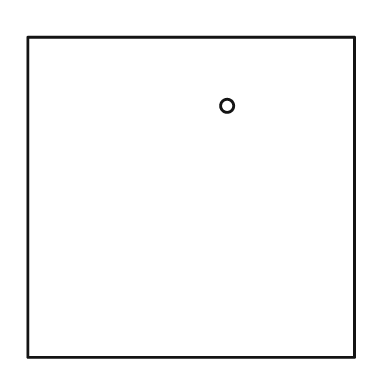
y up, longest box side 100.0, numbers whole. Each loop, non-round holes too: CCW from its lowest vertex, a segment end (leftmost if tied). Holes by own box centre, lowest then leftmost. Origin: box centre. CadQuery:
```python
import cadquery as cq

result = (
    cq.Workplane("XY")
    .moveTo(-50.0, -49.0)
    .lineTo(50.0, -49.0)
    .lineTo(50.0, 49.0)
    .lineTo(-50.0, 49.0)
    .close()
    .moveTo(11.0, 28.0)
    .circle(2.0)
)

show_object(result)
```